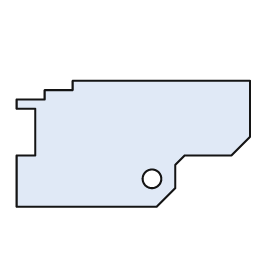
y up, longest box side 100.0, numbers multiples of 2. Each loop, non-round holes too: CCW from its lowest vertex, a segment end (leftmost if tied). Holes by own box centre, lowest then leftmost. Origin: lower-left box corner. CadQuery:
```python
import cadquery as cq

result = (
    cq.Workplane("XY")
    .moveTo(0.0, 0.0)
    .lineTo(60.0, 0.0)
    .lineTo(68.0, 8.0)
    .lineTo(68.0, 18.0)
    .lineTo(72.0, 22.0)
    .lineTo(92.0, 22.0)
    .lineTo(100.0, 30.0)
    .lineTo(100.0, 54.0)
    .lineTo(24.0, 54.0)
    .lineTo(24.0, 50.0)
    .lineTo(12.0, 50.0)
    .lineTo(12.0, 46.0)
    .lineTo(0.0, 46.0)
    .lineTo(0.0, 42.0)
    .lineTo(8.0, 42.0)
    .lineTo(8.0, 22.0)
    .lineTo(0.0, 22.0)
    .close()
    .moveTo(58.0, 12.0)
    .circle(4.0)
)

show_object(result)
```